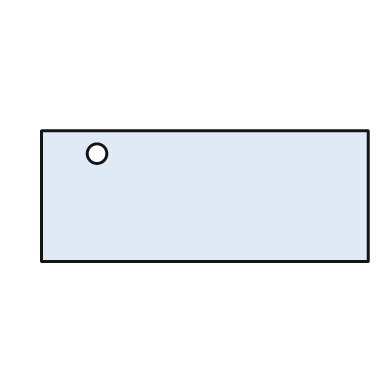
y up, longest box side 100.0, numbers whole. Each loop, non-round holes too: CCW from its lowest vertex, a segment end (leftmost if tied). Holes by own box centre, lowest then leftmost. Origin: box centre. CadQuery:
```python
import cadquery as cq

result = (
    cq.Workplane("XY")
    .moveTo(-50.0, -20.0)
    .lineTo(50.0, -20.0)
    .lineTo(50.0, 20.0)
    .lineTo(-50.0, 20.0)
    .close()
    .moveTo(-33.0, 13.0)
    .circle(3.0)
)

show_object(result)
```